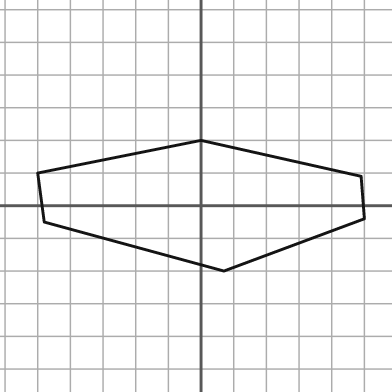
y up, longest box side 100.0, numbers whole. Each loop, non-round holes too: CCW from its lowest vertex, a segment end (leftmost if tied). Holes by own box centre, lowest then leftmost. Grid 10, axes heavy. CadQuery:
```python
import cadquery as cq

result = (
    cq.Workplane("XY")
    .moveTo(7.0, -20.0)
    .lineTo(50.0, -4.0)
    .lineTo(49.0, 9.0)
    .lineTo(0.0, 20.0)
    .lineTo(-50.0, 10.0)
    .lineTo(-48.0, -5.0)
    .close()
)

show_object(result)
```